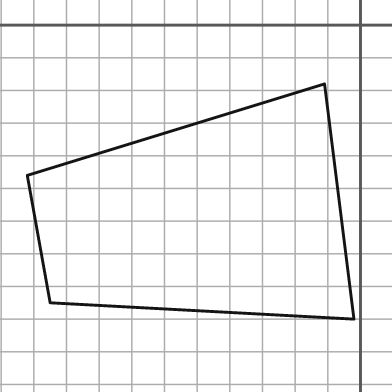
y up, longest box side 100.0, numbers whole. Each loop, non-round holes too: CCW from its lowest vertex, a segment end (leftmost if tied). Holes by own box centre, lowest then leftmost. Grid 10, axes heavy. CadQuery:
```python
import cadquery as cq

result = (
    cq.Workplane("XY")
    .moveTo(-2.0, -90.0)
    .lineTo(-11.0, -18.0)
    .lineTo(-102.0, -46.0)
    .lineTo(-95.0, -85.0)
    .close()
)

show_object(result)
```